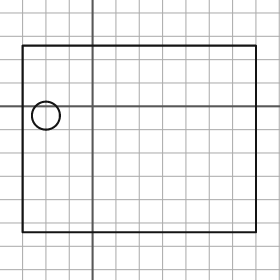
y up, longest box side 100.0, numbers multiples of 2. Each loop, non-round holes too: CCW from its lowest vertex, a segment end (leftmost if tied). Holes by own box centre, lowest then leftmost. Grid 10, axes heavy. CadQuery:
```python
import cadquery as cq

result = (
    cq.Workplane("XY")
    .moveTo(-30.0, -54.0)
    .lineTo(70.0, -54.0)
    .lineTo(70.0, 26.0)
    .lineTo(-30.0, 26.0)
    .close()
    .moveTo(-20.0, -4.0)
    .circle(6.0)
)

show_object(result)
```